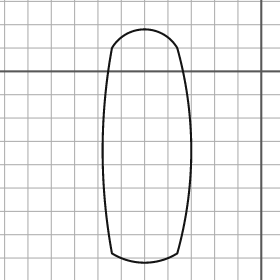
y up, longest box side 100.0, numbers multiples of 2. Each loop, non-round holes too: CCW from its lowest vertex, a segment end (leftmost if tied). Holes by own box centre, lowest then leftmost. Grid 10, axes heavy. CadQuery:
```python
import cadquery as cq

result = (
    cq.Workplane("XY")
    .moveTo(-64.0, -78.0)
    .threePointArc((-50.0, -82.0), (-36.0, -78.0))
    .threePointArc((-30.0, -34.0), (-36.0, 10.0))
    .threePointArc((-50.0, 18.0), (-64.0, 10.0))
    .threePointArc((-68.0, -34.0), (-64.0, -78.0))
    .close()
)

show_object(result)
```